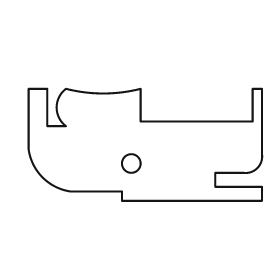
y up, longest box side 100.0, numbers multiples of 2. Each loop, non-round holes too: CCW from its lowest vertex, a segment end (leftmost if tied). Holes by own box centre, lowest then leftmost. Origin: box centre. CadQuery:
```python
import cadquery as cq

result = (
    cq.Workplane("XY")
    .moveTo(-10.0, -24.0)
    .lineTo(50.0, -24.0)
    .lineTo(50.0, -18.0)
    .lineTo(30.0, -18.0)
    .lineTo(30.0, -12.0)
    .lineTo(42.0, -12.0)
    .threePointArc((48.0, -10.0), (50.0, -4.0))
    .lineTo(50.0, 24.0)
    .lineTo(46.0, 24.0)
    .lineTo(46.0, 10.0)
    .lineTo(-2.0, 10.0)
    .lineTo(-2.0, 24.0)
    .threePointArc((-18.0, 22.0), (-34.0, 24.0))
    .threePointArc((-38.0, 16.0), (-34.0, 8.0))
    .lineTo(-42.0, 8.0)
    .lineTo(-42.0, 24.0)
    .lineTo(-50.0, 24.0)
    .lineTo(-50.0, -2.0)
    .threePointArc((-44.0, -14.0), (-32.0, -20.0))
    .lineTo(-10.0, -20.0)
    .close()
    .moveTo(-6.0, -8.0)
    .circle(4.0)
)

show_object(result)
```